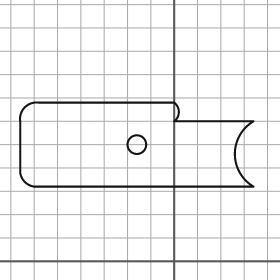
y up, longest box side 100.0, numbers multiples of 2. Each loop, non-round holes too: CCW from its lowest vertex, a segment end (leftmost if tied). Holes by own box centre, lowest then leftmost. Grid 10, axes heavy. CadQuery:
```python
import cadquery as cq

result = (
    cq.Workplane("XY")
    .moveTo(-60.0, 32.0)
    .lineTo(34.0, 32.0)
    .threePointArc((26.0, 46.0), (34.0, 60.0))
    .lineTo(0.0, 60.0)
    .threePointArc((2.0, 64.0), (0.0, 68.0))
    .lineTo(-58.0, 68.0)
    .threePointArc((-64.0, 66.0), (-66.0, 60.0))
    .lineTo(-66.0, 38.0)
    .threePointArc((-64.0, 34.0), (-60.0, 32.0))
    .close()
    .moveTo(-16.0, 50.0)
    .circle(4.0)
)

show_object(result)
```